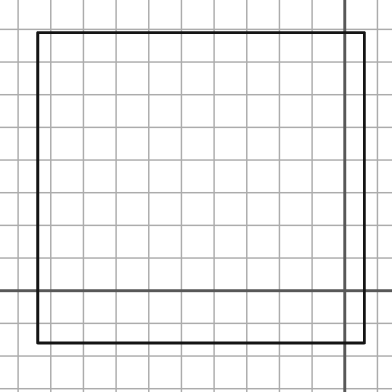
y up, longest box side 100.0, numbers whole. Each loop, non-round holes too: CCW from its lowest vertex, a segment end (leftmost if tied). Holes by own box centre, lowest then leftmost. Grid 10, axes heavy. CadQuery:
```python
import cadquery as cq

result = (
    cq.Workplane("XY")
    .moveTo(-94.0, -16.0)
    .lineTo(6.0, -16.0)
    .lineTo(6.0, 79.0)
    .lineTo(-94.0, 79.0)
    .close()
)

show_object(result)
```